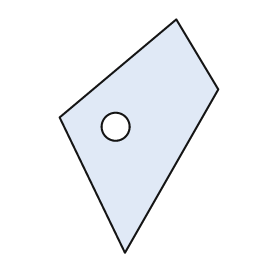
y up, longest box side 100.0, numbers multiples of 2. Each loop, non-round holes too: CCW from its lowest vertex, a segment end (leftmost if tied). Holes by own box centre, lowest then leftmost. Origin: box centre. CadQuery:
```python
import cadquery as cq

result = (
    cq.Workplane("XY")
    .moveTo(-6.0, -50.0)
    .lineTo(34.0, 20.0)
    .lineTo(16.0, 50.0)
    .lineTo(-34.0, 8.0)
    .close()
    .moveTo(-10.0, 4.0)
    .circle(6.0)
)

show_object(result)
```